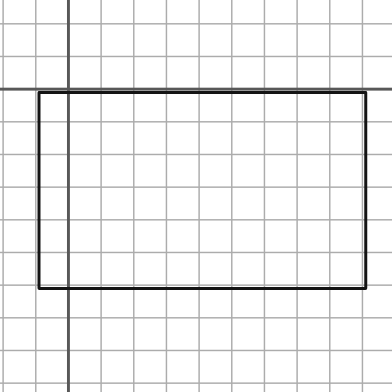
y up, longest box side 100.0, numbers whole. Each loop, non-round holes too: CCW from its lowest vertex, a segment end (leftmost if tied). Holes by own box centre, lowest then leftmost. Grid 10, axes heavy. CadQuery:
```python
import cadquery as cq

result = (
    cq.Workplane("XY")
    .moveTo(-9.0, -61.0)
    .lineTo(91.0, -61.0)
    .lineTo(91.0, -1.0)
    .lineTo(-9.0, -1.0)
    .close()
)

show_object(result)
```